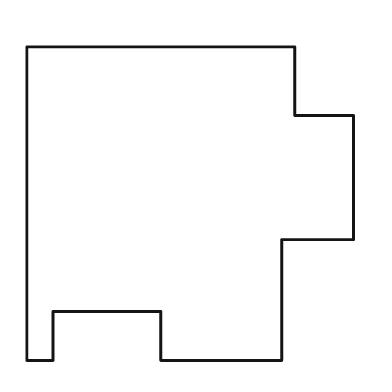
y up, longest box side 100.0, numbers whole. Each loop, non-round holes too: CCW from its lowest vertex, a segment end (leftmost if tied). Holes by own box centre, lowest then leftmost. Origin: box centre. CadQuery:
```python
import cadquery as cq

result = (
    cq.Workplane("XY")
    .moveTo(-50.0, -48.0)
    .lineTo(-42.0, -48.0)
    .lineTo(-42.0, -33.0)
    .lineTo(-9.0, -33.0)
    .lineTo(-9.0, -48.0)
    .lineTo(28.0, -48.0)
    .lineTo(28.0, -11.0)
    .lineTo(50.0, -11.0)
    .lineTo(50.0, 27.0)
    .lineTo(32.0, 27.0)
    .lineTo(32.0, 48.0)
    .lineTo(-50.0, 48.0)
    .close()
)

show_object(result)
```